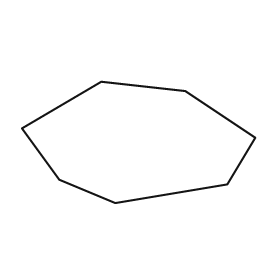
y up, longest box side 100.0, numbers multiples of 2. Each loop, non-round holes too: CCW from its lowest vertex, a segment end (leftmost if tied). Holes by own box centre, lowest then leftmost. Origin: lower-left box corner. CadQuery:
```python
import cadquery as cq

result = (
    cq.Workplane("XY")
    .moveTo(40.0, 0.0)
    .lineTo(88.0, 8.0)
    .lineTo(100.0, 28.0)
    .lineTo(70.0, 48.0)
    .lineTo(34.0, 52.0)
    .lineTo(0.0, 32.0)
    .lineTo(16.0, 10.0)
    .close()
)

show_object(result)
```